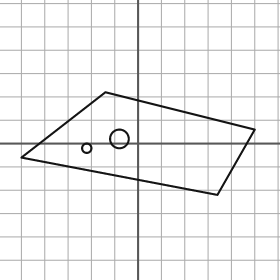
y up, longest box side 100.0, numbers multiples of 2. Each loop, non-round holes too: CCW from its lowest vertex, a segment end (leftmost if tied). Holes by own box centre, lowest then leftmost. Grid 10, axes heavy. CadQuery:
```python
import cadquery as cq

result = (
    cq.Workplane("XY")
    .moveTo(34.0, -22.0)
    .lineTo(50.0, 6.0)
    .lineTo(-14.0, 22.0)
    .lineTo(-50.0, -6.0)
    .close()
    .moveTo(-22.0, -2.0)
    .circle(2.0)
    .moveTo(-8.0, 2.0)
    .circle(4.0)
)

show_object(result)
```